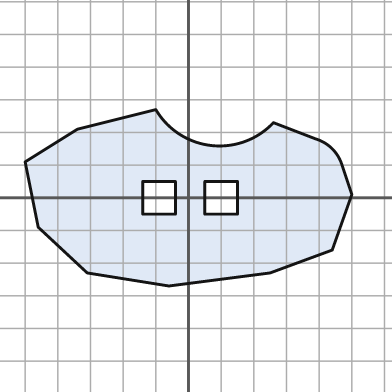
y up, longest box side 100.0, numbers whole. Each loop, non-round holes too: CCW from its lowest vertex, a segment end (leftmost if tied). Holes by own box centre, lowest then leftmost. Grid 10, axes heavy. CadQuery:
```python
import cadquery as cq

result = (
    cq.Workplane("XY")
    .moveTo(-6.0, -27.0)
    .lineTo(25.0, -23.0)
    .lineTo(44.0, -16.0)
    .lineTo(50.0, 1.0)
    .lineTo(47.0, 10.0)
    .threePointArc((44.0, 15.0), (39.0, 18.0))
    .lineTo(26.0, 23.0)
    .threePointArc((7.0, 16.0), (-10.0, 27.0))
    .lineTo(-34.0, 21.0)
    .lineTo(-50.0, 11.0)
    .lineTo(-46.0, -9.0)
    .lineTo(-31.0, -23.0)
    .close()
    .moveTo(-14.0, -5.0)
    .lineTo(-4.0, -5.0)
    .lineTo(-4.0, 5.0)
    .lineTo(-14.0, 5.0)
    .close()
    .moveTo(5.0, -5.0)
    .lineTo(15.0, -5.0)
    .lineTo(15.0, 5.0)
    .lineTo(5.0, 5.0)
    .close()
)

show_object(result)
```